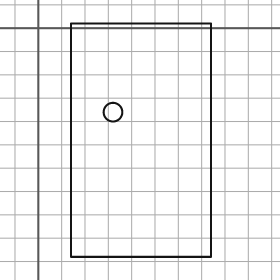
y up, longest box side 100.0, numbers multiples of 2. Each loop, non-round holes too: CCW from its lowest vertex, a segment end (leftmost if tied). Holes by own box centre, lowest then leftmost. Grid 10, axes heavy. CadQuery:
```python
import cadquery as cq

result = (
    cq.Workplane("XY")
    .moveTo(14.0, -98.0)
    .lineTo(74.0, -98.0)
    .lineTo(74.0, 2.0)
    .lineTo(14.0, 2.0)
    .close()
    .moveTo(32.0, -36.0)
    .circle(4.0)
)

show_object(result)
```